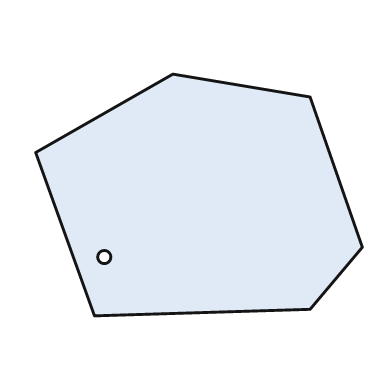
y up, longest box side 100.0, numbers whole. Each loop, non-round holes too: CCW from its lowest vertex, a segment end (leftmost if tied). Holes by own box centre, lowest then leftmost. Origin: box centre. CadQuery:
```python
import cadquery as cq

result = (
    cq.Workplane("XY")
    .moveTo(-32.0, -37.0)
    .lineTo(34.0, -35.0)
    .lineTo(50.0, -16.0)
    .lineTo(34.0, 30.0)
    .lineTo(-8.0, 37.0)
    .lineTo(-50.0, 13.0)
    .close()
    .moveTo(-29.0, -19.0)
    .circle(2.0)
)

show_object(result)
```